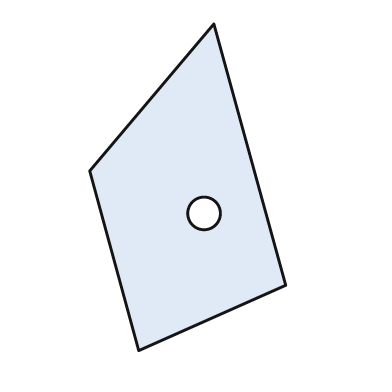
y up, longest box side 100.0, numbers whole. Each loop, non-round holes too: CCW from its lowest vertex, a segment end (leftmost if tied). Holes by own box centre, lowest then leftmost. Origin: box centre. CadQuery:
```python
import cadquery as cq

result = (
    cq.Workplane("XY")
    .moveTo(-15.0, -50.0)
    .lineTo(30.0, -30.0)
    .lineTo(8.0, 50.0)
    .lineTo(-30.0, 5.0)
    .close()
    .moveTo(5.0, -8.0)
    .circle(5.0)
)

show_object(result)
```